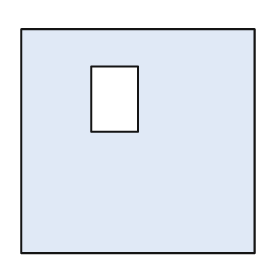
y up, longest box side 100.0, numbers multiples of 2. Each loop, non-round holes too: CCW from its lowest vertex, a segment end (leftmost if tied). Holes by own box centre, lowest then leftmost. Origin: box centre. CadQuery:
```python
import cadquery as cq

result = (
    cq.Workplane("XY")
    .moveTo(-50.0, -48.0)
    .lineTo(50.0, -48.0)
    .lineTo(50.0, 48.0)
    .lineTo(-50.0, 48.0)
    .close()
    .moveTo(-20.0, 4.0)
    .lineTo(0.0, 4.0)
    .lineTo(0.0, 32.0)
    .lineTo(-20.0, 32.0)
    .close()
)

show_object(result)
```